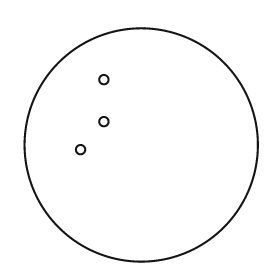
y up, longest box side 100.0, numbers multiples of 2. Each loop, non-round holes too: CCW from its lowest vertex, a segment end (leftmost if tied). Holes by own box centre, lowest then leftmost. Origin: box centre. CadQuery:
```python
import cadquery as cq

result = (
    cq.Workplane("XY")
    .moveTo(0.0, 0.0)
    .circle(50.0)
    .moveTo(-26.0, -2.0)
    .circle(2.0)
    .moveTo(-16.0, 10.0)
    .circle(2.0)
    .moveTo(-16.0, 28.0)
    .circle(2.0)
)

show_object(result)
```